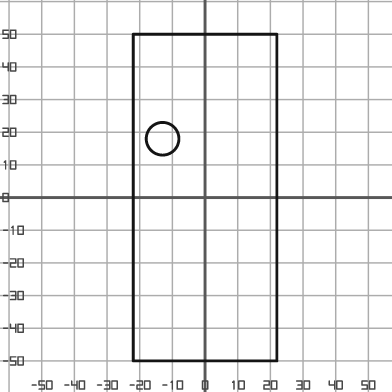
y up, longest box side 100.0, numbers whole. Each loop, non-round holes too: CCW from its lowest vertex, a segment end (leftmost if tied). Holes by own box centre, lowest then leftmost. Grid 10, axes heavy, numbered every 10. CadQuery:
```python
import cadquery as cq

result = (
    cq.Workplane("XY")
    .moveTo(-22.0, -50.0)
    .lineTo(22.0, -50.0)
    .lineTo(22.0, 50.0)
    .lineTo(-22.0, 50.0)
    .close()
    .moveTo(-13.0, 18.0)
    .circle(5.0)
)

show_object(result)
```